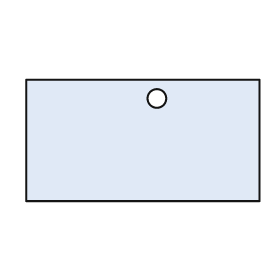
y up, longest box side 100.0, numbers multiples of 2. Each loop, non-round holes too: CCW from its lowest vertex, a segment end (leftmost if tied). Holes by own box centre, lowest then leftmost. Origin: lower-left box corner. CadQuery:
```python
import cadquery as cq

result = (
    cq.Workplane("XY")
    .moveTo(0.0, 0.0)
    .lineTo(100.0, 0.0)
    .lineTo(100.0, 52.0)
    .lineTo(0.0, 52.0)
    .close()
    .moveTo(56.0, 44.0)
    .circle(4.0)
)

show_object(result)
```